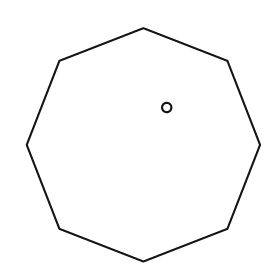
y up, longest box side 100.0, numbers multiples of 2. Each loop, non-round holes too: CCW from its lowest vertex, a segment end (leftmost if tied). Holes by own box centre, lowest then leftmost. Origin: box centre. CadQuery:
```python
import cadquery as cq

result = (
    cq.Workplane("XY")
    .moveTo(0.0, -50.0)
    .lineTo(36.0, -36.0)
    .lineTo(50.0, 0.0)
    .lineTo(36.0, 36.0)
    .lineTo(0.0, 50.0)
    .lineTo(-36.0, 36.0)
    .lineTo(-50.0, 0.0)
    .lineTo(-36.0, -36.0)
    .close()
    .moveTo(10.0, 16.0)
    .circle(2.0)
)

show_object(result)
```